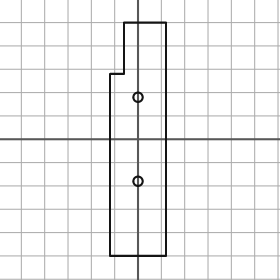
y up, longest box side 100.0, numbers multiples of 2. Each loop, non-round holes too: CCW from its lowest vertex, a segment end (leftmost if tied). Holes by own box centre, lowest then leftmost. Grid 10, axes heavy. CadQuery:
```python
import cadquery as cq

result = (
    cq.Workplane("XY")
    .moveTo(-12.0, -50.0)
    .lineTo(12.0, -50.0)
    .lineTo(12.0, 50.0)
    .lineTo(-6.0, 50.0)
    .lineTo(-6.0, 28.0)
    .lineTo(-12.0, 28.0)
    .close()
    .moveTo(0.0, -18.0)
    .circle(2.0)
    .moveTo(0.0, 18.0)
    .circle(2.0)
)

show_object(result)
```